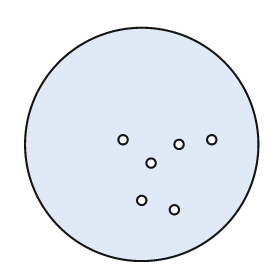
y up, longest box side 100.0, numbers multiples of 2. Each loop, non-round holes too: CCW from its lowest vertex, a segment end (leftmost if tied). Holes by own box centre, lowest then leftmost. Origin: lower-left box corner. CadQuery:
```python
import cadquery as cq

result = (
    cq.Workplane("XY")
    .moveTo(50.0, 50.0)
    .circle(50.0)
    .moveTo(64.0, 22.0)
    .circle(2.0)
    .moveTo(50.0, 26.0)
    .circle(2.0)
    .moveTo(54.0, 42.0)
    .circle(2.0)
    .moveTo(66.0, 50.0)
    .circle(2.0)
    .moveTo(42.0, 52.0)
    .circle(2.0)
    .moveTo(80.0, 52.0)
    .circle(2.0)
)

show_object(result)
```